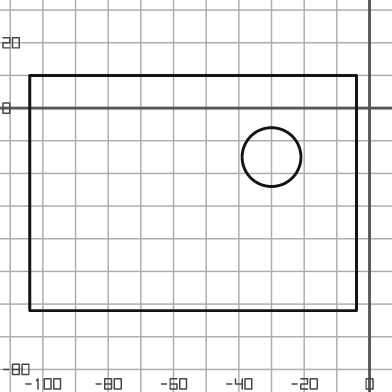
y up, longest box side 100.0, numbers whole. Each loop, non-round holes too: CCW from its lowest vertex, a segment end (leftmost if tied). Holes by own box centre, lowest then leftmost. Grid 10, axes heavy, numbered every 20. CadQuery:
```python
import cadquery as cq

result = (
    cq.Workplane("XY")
    .moveTo(-104.0, -62.0)
    .lineTo(-4.0, -62.0)
    .lineTo(-4.0, 10.0)
    .lineTo(-104.0, 10.0)
    .close()
    .moveTo(-30.0, -15.0)
    .circle(9.0)
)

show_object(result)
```